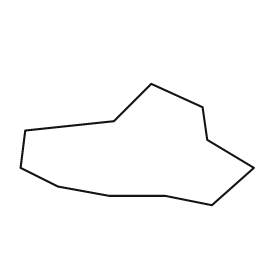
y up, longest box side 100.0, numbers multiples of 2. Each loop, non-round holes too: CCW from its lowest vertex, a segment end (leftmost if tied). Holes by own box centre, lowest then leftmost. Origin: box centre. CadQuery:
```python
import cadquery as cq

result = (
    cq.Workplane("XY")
    .moveTo(32.0, -26.0)
    .lineTo(50.0, -10.0)
    .lineTo(30.0, 2.0)
    .lineTo(28.0, 16.0)
    .lineTo(6.0, 26.0)
    .lineTo(-10.0, 10.0)
    .lineTo(-48.0, 6.0)
    .lineTo(-50.0, -10.0)
    .lineTo(-34.0, -18.0)
    .lineTo(-12.0, -22.0)
    .lineTo(12.0, -22.0)
    .close()
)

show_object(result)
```